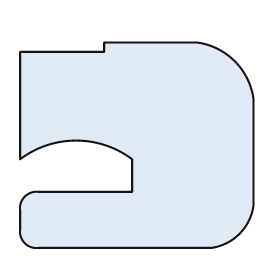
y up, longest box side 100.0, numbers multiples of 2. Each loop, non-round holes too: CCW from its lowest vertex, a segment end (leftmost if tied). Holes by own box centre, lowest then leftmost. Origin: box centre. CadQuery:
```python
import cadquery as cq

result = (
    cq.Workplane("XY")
    .moveTo(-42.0, -44.0)
    .lineTo(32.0, -44.0)
    .threePointArc((44.0, -38.0), (50.0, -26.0))
    .lineTo(50.0, 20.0)
    .threePointArc((42.0, 36.0), (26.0, 44.0))
    .lineTo(-14.0, 44.0)
    .lineTo(-14.0, 40.0)
    .lineTo(-50.0, 40.0)
    .lineTo(-50.0, -6.0)
    .threePointArc((-26.0, 2.0), (-2.0, -6.0))
    .lineTo(-2.0, -20.0)
    .lineTo(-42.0, -20.0)
    .threePointArc((-48.0, -22.0), (-50.0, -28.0))
    .lineTo(-50.0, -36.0)
    .threePointArc((-48.0, -42.0), (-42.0, -44.0))
    .close()
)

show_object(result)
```